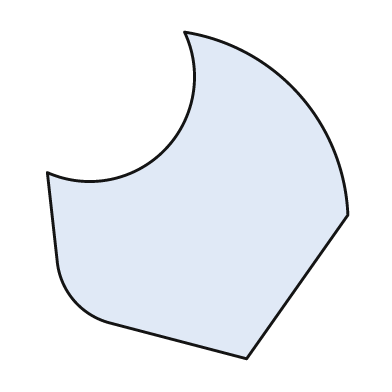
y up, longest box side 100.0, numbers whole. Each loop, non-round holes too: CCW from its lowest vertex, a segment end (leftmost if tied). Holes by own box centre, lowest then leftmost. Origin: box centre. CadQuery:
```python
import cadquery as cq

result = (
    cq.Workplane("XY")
    .moveTo(15.0, -50.0)
    .lineTo(46.0, -6.0)
    .threePointArc((31.0, 31.0), (-4.0, 50.0))
    .threePointArc((-10.0, 14.0), (-46.0, 7.0))
    .lineTo(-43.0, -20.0)
    .threePointArc((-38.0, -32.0), (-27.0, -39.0))
    .close()
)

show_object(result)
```